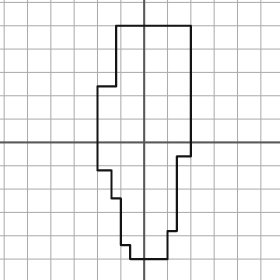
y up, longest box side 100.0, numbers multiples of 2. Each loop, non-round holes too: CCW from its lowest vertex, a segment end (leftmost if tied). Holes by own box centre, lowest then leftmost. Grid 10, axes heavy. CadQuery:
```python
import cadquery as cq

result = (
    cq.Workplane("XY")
    .moveTo(-6.0, -50.0)
    .lineTo(10.0, -50.0)
    .lineTo(10.0, -38.0)
    .lineTo(14.0, -38.0)
    .lineTo(14.0, -6.0)
    .lineTo(20.0, -6.0)
    .lineTo(20.0, 50.0)
    .lineTo(-12.0, 50.0)
    .lineTo(-12.0, 24.0)
    .lineTo(-20.0, 24.0)
    .lineTo(-20.0, -12.0)
    .lineTo(-14.0, -12.0)
    .lineTo(-14.0, -24.0)
    .lineTo(-10.0, -24.0)
    .lineTo(-10.0, -44.0)
    .lineTo(-6.0, -44.0)
    .close()
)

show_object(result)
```